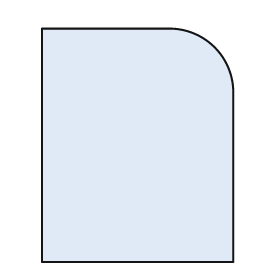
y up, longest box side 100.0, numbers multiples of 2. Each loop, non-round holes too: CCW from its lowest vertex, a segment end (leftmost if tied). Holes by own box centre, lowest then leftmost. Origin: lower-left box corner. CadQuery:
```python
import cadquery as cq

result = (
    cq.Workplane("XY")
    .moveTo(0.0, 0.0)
    .lineTo(82.0, 0.0)
    .lineTo(82.0, 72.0)
    .threePointArc((74.0, 92.0), (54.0, 100.0))
    .lineTo(0.0, 100.0)
    .close()
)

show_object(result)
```